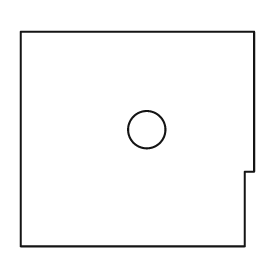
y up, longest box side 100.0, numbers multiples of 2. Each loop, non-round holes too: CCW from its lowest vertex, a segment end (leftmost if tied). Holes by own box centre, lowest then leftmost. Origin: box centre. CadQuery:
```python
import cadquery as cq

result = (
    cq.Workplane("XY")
    .moveTo(-50.0, -46.0)
    .lineTo(46.0, -46.0)
    .lineTo(46.0, -14.0)
    .lineTo(50.0, -14.0)
    .lineTo(50.0, 46.0)
    .lineTo(-50.0, 46.0)
    .close()
    .moveTo(4.0, 4.0)
    .circle(8.0)
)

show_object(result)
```